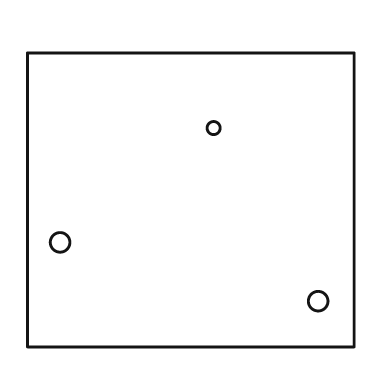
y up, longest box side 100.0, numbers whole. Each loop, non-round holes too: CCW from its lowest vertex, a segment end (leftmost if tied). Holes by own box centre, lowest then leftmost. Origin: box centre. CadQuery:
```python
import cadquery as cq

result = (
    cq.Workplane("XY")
    .moveTo(-50.0, -45.0)
    .lineTo(50.0, -45.0)
    .lineTo(50.0, 45.0)
    .lineTo(-50.0, 45.0)
    .close()
    .moveTo(39.0, -31.0)
    .circle(3.0)
    .moveTo(-40.0, -13.0)
    .circle(3.0)
    .moveTo(7.0, 22.0)
    .circle(2.0)
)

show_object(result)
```